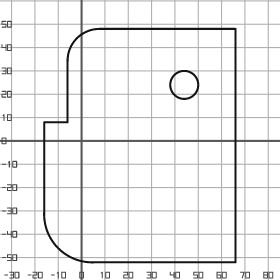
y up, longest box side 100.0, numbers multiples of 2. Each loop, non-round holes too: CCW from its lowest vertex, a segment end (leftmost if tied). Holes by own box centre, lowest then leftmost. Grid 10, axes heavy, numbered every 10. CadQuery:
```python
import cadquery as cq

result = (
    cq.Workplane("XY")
    .moveTo(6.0, -52.0)
    .lineTo(66.0, -52.0)
    .lineTo(66.0, 48.0)
    .lineTo(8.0, 48.0)
    .threePointArc((-2.0, 44.0), (-6.0, 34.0))
    .lineTo(-6.0, 8.0)
    .lineTo(-16.0, 8.0)
    .lineTo(-16.0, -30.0)
    .threePointArc((-10.0, -46.0), (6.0, -52.0))
    .close()
    .moveTo(44.0, 24.0)
    .circle(6.0)
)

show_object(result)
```